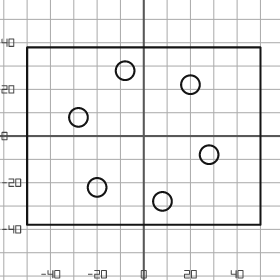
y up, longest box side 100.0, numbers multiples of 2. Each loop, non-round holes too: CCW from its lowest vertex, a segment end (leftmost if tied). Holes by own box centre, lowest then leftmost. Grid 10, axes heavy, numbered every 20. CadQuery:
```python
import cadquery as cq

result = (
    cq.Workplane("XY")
    .moveTo(-50.0, -38.0)
    .lineTo(50.0, -38.0)
    .lineTo(50.0, 38.0)
    .lineTo(-50.0, 38.0)
    .close()
    .moveTo(8.0, -28.0)
    .circle(4.0)
    .moveTo(-20.0, -22.0)
    .circle(4.0)
    .moveTo(28.0, -8.0)
    .circle(4.0)
    .moveTo(-28.0, 8.0)
    .circle(4.0)
    .moveTo(20.0, 22.0)
    .circle(4.0)
    .moveTo(-8.0, 28.0)
    .circle(4.0)
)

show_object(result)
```